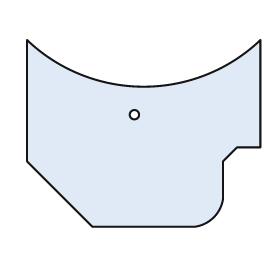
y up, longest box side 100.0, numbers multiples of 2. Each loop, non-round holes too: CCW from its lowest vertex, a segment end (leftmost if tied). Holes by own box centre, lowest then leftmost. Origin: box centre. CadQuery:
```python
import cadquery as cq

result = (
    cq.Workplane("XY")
    .moveTo(-22.0, -40.0)
    .lineTo(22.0, -40.0)
    .threePointArc((30.0, -36.0), (34.0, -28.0))
    .lineTo(34.0, -12.0)
    .lineTo(40.0, -6.0)
    .lineTo(50.0, -6.0)
    .lineTo(50.0, 40.0)
    .threePointArc((0.0, 20.0), (-50.0, 40.0))
    .lineTo(-50.0, -12.0)
    .close()
    .moveTo(-4.0, 8.0)
    .circle(2.0)
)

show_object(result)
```